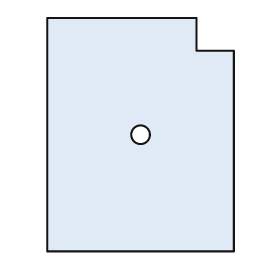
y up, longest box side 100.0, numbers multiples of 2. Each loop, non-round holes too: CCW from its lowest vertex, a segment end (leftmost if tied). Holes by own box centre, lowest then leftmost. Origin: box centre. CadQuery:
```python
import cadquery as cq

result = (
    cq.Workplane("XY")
    .moveTo(-40.0, -50.0)
    .lineTo(40.0, -50.0)
    .lineTo(40.0, 36.0)
    .lineTo(24.0, 36.0)
    .lineTo(24.0, 50.0)
    .lineTo(-40.0, 50.0)
    .close()
    .moveTo(0.0, 0.0)
    .circle(4.0)
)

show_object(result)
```